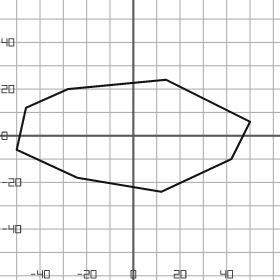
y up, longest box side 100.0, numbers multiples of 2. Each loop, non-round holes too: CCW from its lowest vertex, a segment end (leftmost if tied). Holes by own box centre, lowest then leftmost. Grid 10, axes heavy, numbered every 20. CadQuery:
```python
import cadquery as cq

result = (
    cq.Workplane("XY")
    .moveTo(12.0, -24.0)
    .lineTo(42.0, -10.0)
    .lineTo(50.0, 6.0)
    .lineTo(14.0, 24.0)
    .lineTo(-28.0, 20.0)
    .lineTo(-46.0, 12.0)
    .lineTo(-50.0, -6.0)
    .lineTo(-24.0, -18.0)
    .close()
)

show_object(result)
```